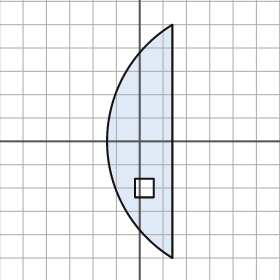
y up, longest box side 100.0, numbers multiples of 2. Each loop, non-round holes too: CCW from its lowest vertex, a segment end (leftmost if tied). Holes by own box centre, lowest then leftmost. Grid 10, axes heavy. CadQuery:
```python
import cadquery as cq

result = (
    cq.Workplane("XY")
    .moveTo(14.0, -50.0)
    .lineTo(14.0, 50.0)
    .threePointArc((-14.0, 0.0), (14.0, -50.0))
    .close()
    .moveTo(-2.0, -24.0)
    .lineTo(6.0, -24.0)
    .lineTo(6.0, -16.0)
    .lineTo(-2.0, -16.0)
    .close()
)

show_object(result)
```